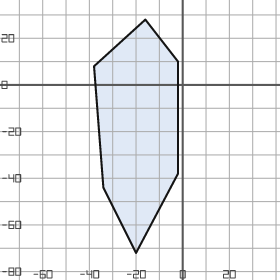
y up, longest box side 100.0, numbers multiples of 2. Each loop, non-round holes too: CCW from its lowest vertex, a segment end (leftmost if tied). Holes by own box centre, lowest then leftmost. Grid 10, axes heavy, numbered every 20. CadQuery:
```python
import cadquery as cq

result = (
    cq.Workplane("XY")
    .moveTo(-20.0, -72.0)
    .lineTo(-2.0, -38.0)
    .lineTo(-2.0, 10.0)
    .lineTo(-16.0, 28.0)
    .lineTo(-38.0, 8.0)
    .lineTo(-34.0, -44.0)
    .close()
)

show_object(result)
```